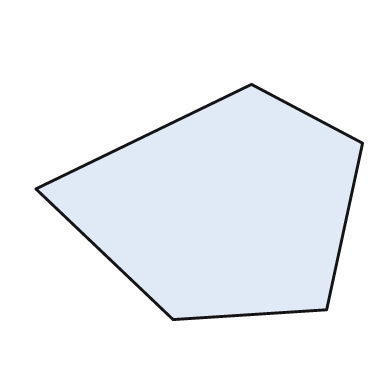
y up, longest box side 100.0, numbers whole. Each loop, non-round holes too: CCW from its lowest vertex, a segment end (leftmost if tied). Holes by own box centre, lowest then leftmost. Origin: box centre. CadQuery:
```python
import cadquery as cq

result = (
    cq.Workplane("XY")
    .moveTo(-8.0, -36.0)
    .lineTo(39.0, -33.0)
    .lineTo(50.0, 18.0)
    .lineTo(16.0, 36.0)
    .lineTo(-50.0, 4.0)
    .close()
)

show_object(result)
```